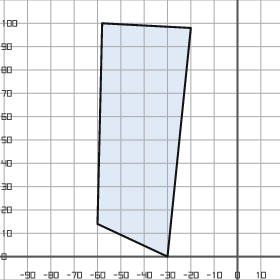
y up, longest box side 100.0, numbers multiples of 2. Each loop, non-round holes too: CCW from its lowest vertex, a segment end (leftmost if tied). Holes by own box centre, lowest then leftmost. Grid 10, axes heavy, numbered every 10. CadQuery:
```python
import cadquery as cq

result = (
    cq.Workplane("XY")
    .moveTo(-30.0, 0.0)
    .lineTo(-20.0, 98.0)
    .lineTo(-58.0, 100.0)
    .lineTo(-60.0, 14.0)
    .close()
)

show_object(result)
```